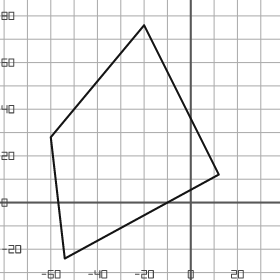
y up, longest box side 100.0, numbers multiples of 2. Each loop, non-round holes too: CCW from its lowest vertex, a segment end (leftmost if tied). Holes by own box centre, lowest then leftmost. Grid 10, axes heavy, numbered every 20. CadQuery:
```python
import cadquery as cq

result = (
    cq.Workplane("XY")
    .moveTo(-54.0, -24.0)
    .lineTo(12.0, 12.0)
    .lineTo(-20.0, 76.0)
    .lineTo(-60.0, 28.0)
    .close()
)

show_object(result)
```